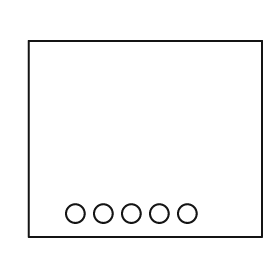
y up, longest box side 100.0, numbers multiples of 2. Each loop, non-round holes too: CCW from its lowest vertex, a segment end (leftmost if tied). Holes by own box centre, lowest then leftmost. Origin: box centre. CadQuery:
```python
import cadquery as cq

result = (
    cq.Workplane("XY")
    .moveTo(-50.0, -42.0)
    .lineTo(50.0, -42.0)
    .lineTo(50.0, 42.0)
    .lineTo(-50.0, 42.0)
    .close()
    .moveTo(-30.0, -32.0)
    .circle(4.0)
    .moveTo(-18.0, -32.0)
    .circle(4.0)
    .moveTo(-6.0, -32.0)
    .circle(4.0)
    .moveTo(6.0, -32.0)
    .circle(4.0)
    .moveTo(18.0, -32.0)
    .circle(4.0)
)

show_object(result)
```